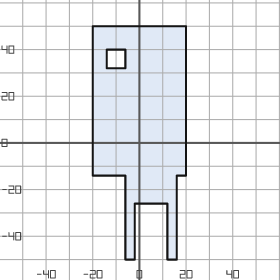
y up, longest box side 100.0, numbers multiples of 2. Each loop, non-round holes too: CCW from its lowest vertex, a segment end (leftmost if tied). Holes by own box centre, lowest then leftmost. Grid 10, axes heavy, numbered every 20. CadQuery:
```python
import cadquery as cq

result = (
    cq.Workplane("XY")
    .moveTo(-6.0, -50.0)
    .lineTo(-2.0, -50.0)
    .lineTo(-2.0, -26.0)
    .lineTo(12.0, -26.0)
    .lineTo(12.0, -50.0)
    .lineTo(16.0, -50.0)
    .lineTo(16.0, -14.0)
    .lineTo(20.0, -14.0)
    .lineTo(20.0, 50.0)
    .lineTo(-20.0, 50.0)
    .lineTo(-20.0, -14.0)
    .lineTo(-6.0, -14.0)
    .close()
    .moveTo(-14.0, 32.0)
    .lineTo(-6.0, 32.0)
    .lineTo(-6.0, 40.0)
    .lineTo(-14.0, 40.0)
    .close()
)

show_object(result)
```